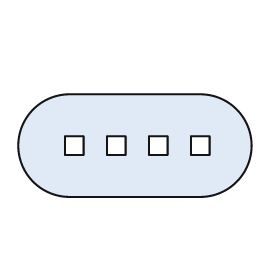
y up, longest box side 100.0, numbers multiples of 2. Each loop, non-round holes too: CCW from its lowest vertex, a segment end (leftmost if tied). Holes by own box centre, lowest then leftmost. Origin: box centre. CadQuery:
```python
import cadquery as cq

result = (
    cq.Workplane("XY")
    .moveTo(-28.0, -22.0)
    .lineTo(28.0, -22.0)
    .threePointArc((50.0, 0.0), (28.0, 22.0))
    .lineTo(-28.0, 22.0)
    .threePointArc((-50.0, 0.0), (-28.0, -22.0))
    .close()
    .moveTo(-30.0, -4.0)
    .lineTo(-22.0, -4.0)
    .lineTo(-22.0, 4.0)
    .lineTo(-30.0, 4.0)
    .close()
    .moveTo(-12.0, -4.0)
    .lineTo(-4.0, -4.0)
    .lineTo(-4.0, 4.0)
    .lineTo(-12.0, 4.0)
    .close()
    .moveTo(6.0, -4.0)
    .lineTo(14.0, -4.0)
    .lineTo(14.0, 4.0)
    .lineTo(6.0, 4.0)
    .close()
    .moveTo(24.0, -4.0)
    .lineTo(32.0, -4.0)
    .lineTo(32.0, 4.0)
    .lineTo(24.0, 4.0)
    .close()
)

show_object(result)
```